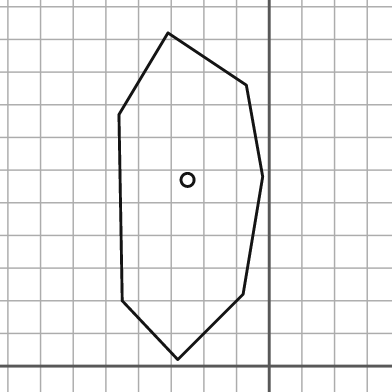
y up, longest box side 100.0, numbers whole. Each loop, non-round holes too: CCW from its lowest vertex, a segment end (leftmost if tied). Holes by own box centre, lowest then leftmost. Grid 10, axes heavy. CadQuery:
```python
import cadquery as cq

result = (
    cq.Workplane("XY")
    .moveTo(-28.0, 2.0)
    .lineTo(-8.0, 22.0)
    .lineTo(-2.0, 58.0)
    .lineTo(-7.0, 86.0)
    .lineTo(-31.0, 102.0)
    .lineTo(-46.0, 77.0)
    .lineTo(-45.0, 20.0)
    .close()
    .moveTo(-25.0, 57.0)
    .circle(2.0)
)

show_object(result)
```